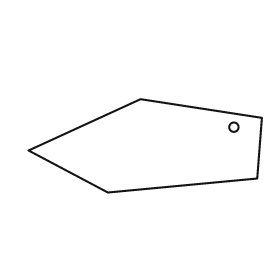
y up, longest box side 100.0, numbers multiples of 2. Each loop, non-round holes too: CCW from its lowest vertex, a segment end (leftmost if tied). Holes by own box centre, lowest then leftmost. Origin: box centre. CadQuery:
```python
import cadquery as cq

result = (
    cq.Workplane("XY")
    .moveTo(-16.0, -20.0)
    .lineTo(48.0, -14.0)
    .lineTo(50.0, 12.0)
    .lineTo(-2.0, 20.0)
    .lineTo(-50.0, -2.0)
    .close()
    .moveTo(38.0, 8.0)
    .circle(2.0)
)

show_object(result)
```